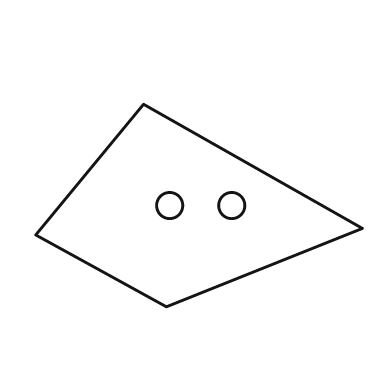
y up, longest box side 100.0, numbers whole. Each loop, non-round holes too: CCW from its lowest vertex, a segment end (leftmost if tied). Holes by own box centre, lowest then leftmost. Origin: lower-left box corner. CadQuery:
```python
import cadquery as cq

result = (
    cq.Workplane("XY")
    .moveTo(40.0, 0.0)
    .lineTo(100.0, 24.0)
    .lineTo(33.0, 62.0)
    .lineTo(0.0, 22.0)
    .close()
    .moveTo(41.0, 31.0)
    .circle(4.0)
    .moveTo(60.0, 31.0)
    .circle(4.0)
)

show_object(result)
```